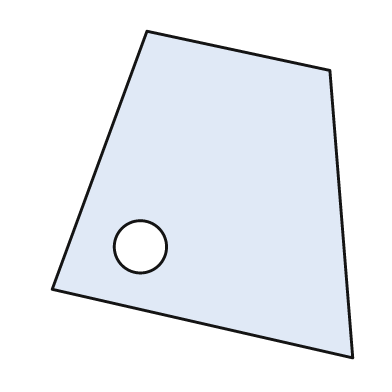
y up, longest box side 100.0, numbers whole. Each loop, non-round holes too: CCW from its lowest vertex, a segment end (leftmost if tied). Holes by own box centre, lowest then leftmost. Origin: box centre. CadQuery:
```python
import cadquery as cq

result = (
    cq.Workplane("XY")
    .moveTo(46.0, -50.0)
    .lineTo(39.0, 38.0)
    .lineTo(-17.0, 50.0)
    .lineTo(-46.0, -29.0)
    .close()
    .moveTo(-19.0, -16.0)
    .circle(8.0)
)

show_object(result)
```